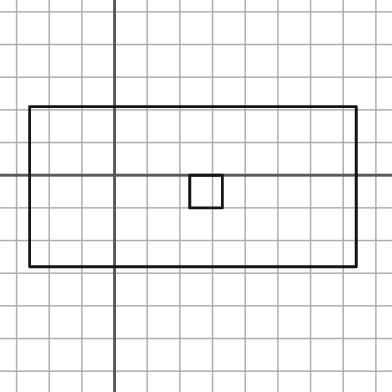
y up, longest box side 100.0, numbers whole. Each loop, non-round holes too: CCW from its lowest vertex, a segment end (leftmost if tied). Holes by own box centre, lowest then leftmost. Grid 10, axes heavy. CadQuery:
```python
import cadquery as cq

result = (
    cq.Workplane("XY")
    .moveTo(-26.0, -28.0)
    .lineTo(74.0, -28.0)
    .lineTo(74.0, 21.0)
    .lineTo(-26.0, 21.0)
    .close()
    .moveTo(23.0, -10.0)
    .lineTo(33.0, -10.0)
    .lineTo(33.0, 0.0)
    .lineTo(23.0, 0.0)
    .close()
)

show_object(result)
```